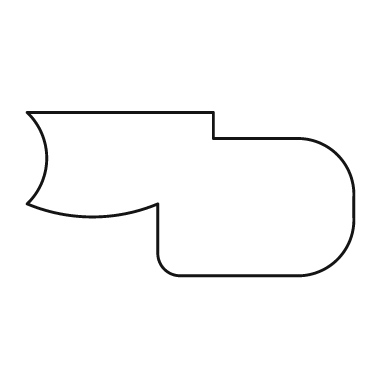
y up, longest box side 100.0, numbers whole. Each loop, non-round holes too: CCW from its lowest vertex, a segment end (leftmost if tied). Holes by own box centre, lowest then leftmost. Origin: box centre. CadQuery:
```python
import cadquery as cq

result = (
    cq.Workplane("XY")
    .moveTo(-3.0, -25.0)
    .lineTo(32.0, -25.0)
    .threePointArc((45.0, -20.0), (50.0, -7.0))
    .lineTo(50.0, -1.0)
    .threePointArc((45.0, 12.0), (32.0, 17.0))
    .lineTo(7.0, 17.0)
    .lineTo(7.0, 25.0)
    .lineTo(-50.0, 25.0)
    .threePointArc((-44.0, 11.0), (-50.0, -3.0))
    .threePointArc((-30.0, -7.0), (-10.0, -3.0))
    .lineTo(-10.0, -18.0)
    .threePointArc((-8.0, -23.0), (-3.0, -25.0))
    .close()
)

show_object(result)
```